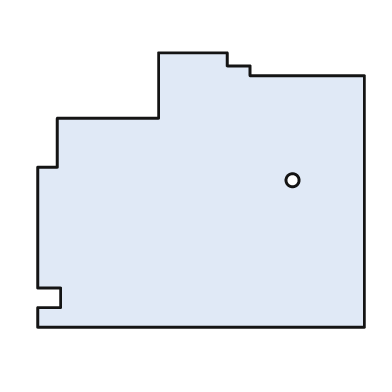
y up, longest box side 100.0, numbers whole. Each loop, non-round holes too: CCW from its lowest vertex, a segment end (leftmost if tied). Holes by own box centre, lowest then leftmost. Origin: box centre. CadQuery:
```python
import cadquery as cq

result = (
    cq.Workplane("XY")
    .moveTo(-50.0, -42.0)
    .lineTo(50.0, -42.0)
    .lineTo(50.0, 35.0)
    .lineTo(15.0, 35.0)
    .lineTo(15.0, 38.0)
    .lineTo(8.0, 38.0)
    .lineTo(8.0, 42.0)
    .lineTo(-13.0, 42.0)
    .lineTo(-13.0, 22.0)
    .lineTo(-44.0, 22.0)
    .lineTo(-44.0, 7.0)
    .lineTo(-50.0, 7.0)
    .lineTo(-50.0, -30.0)
    .lineTo(-43.0, -30.0)
    .lineTo(-43.0, -36.0)
    .lineTo(-50.0, -36.0)
    .close()
    .moveTo(28.0, 3.0)
    .circle(2.0)
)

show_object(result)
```